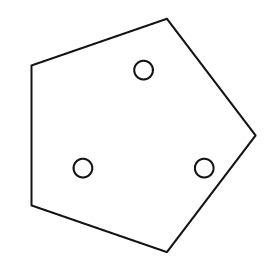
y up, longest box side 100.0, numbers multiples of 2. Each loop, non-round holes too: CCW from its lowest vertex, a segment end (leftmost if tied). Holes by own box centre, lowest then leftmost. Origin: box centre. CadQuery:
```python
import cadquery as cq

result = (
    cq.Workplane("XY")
    .moveTo(10.0, -50.0)
    .lineTo(48.0, 0.0)
    .lineTo(10.0, 50.0)
    .lineTo(-48.0, 30.0)
    .lineTo(-48.0, -30.0)
    .close()
    .moveTo(-26.0, -14.0)
    .circle(4.0)
    .moveTo(26.0, -14.0)
    .circle(4.0)
    .moveTo(0.0, 28.0)
    .circle(4.0)
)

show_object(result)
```